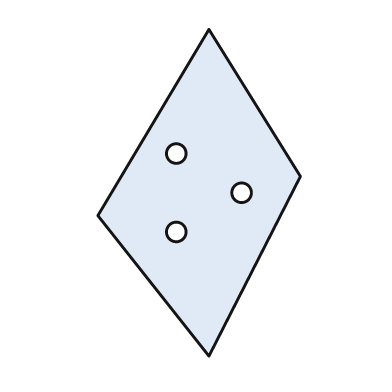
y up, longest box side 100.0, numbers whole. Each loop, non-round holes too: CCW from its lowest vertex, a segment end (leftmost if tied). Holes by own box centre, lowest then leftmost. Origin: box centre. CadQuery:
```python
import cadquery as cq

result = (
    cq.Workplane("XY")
    .moveTo(3.0, -50.0)
    .lineTo(31.0, 5.0)
    .lineTo(3.0, 50.0)
    .lineTo(-31.0, -7.0)
    .close()
    .moveTo(-7.0, -12.0)
    .circle(3.0)
    .moveTo(13.0, 0.0)
    .circle(3.0)
    .moveTo(-7.0, 12.0)
    .circle(3.0)
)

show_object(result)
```